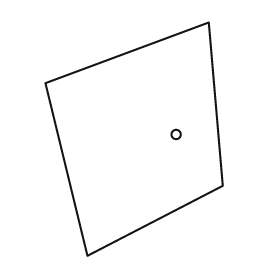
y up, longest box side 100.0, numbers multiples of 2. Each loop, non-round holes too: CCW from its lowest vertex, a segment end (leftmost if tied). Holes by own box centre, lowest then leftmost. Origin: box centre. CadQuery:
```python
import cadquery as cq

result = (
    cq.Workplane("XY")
    .moveTo(-20.0, -50.0)
    .lineTo(38.0, -20.0)
    .lineTo(32.0, 50.0)
    .lineTo(-38.0, 24.0)
    .close()
    .moveTo(18.0, 2.0)
    .circle(2.0)
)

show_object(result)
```